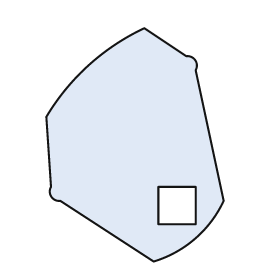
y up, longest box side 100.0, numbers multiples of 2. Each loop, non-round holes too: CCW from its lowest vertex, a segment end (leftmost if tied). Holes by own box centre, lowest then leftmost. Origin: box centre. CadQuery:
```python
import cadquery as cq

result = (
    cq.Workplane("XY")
    .moveTo(8.0, -50.0)
    .threePointArc((26.0, -40.0), (38.0, -24.0))
    .lineTo(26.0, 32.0)
    .threePointArc((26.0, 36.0), (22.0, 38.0))
    .lineTo(4.0, 50.0)
    .threePointArc((-20.0, 34.0), (-38.0, 12.0))
    .lineTo(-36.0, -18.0)
    .threePointArc((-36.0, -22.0), (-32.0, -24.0))
    .close()
    .moveTo(10.0, -34.0)
    .lineTo(26.0, -34.0)
    .lineTo(26.0, -18.0)
    .lineTo(10.0, -18.0)
    .close()
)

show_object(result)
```